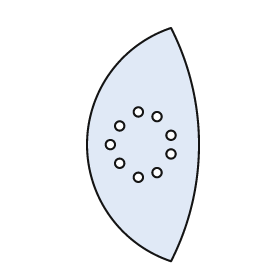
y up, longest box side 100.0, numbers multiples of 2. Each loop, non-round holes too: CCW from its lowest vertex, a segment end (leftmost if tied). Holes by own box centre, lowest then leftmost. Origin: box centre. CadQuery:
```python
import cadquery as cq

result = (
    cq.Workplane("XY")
    .moveTo(12.0, -50.0)
    .threePointArc((24.0, 0.0), (12.0, 50.0))
    .threePointArc((-24.0, 0.0), (12.0, -50.0))
    .close()
    .moveTo(-2.0, -14.0)
    .circle(2.0)
    .moveTo(6.0, -12.0)
    .circle(2.0)
    .moveTo(-10.0, -8.0)
    .circle(2.0)
    .moveTo(12.0, -4.0)
    .circle(2.0)
    .moveTo(-14.0, 0.0)
    .circle(2.0)
    .moveTo(12.0, 4.0)
    .circle(2.0)
    .moveTo(-10.0, 8.0)
    .circle(2.0)
    .moveTo(6.0, 12.0)
    .circle(2.0)
    .moveTo(-2.0, 14.0)
    .circle(2.0)
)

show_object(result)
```